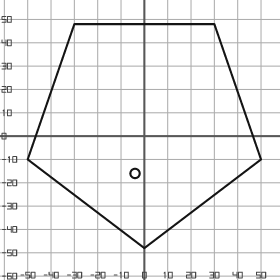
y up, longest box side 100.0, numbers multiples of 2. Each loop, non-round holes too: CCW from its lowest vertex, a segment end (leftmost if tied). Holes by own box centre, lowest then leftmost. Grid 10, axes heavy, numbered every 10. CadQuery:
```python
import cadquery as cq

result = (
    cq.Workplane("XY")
    .moveTo(0.0, -48.0)
    .lineTo(50.0, -10.0)
    .lineTo(30.0, 48.0)
    .lineTo(-30.0, 48.0)
    .lineTo(-50.0, -10.0)
    .close()
    .moveTo(-4.0, -16.0)
    .circle(2.0)
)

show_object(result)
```